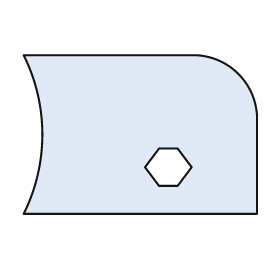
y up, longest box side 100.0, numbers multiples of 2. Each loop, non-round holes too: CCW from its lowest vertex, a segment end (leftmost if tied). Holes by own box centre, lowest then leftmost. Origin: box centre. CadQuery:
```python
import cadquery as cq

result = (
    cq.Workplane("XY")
    .moveTo(-50.0, -34.0)
    .lineTo(50.0, -34.0)
    .lineTo(50.0, 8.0)
    .threePointArc((42.0, 26.0), (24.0, 34.0))
    .lineTo(-50.0, 34.0)
    .threePointArc((-42.0, 0.0), (-50.0, -34.0))
    .close()
    .moveTo(8.0, -22.0)
    .lineTo(16.0, -22.0)
    .lineTo(22.0, -14.0)
    .lineTo(16.0, -6.0)
    .lineTo(8.0, -6.0)
    .lineTo(2.0, -14.0)
    .close()
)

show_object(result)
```